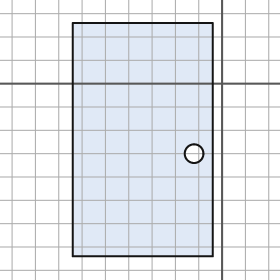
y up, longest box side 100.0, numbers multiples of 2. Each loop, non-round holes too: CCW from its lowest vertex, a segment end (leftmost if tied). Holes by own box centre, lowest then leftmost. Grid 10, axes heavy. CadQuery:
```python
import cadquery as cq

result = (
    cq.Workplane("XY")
    .moveTo(-64.0, -74.0)
    .lineTo(-4.0, -74.0)
    .lineTo(-4.0, 26.0)
    .lineTo(-64.0, 26.0)
    .close()
    .moveTo(-12.0, -30.0)
    .circle(4.0)
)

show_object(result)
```